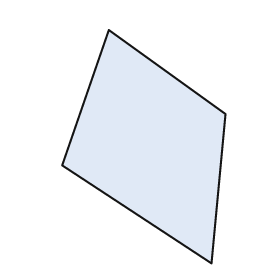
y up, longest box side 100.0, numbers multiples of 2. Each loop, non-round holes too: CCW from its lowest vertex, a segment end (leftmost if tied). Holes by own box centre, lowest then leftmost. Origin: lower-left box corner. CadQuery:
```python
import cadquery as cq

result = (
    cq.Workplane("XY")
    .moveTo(64.0, 0.0)
    .lineTo(70.0, 64.0)
    .lineTo(20.0, 100.0)
    .lineTo(0.0, 42.0)
    .close()
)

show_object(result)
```